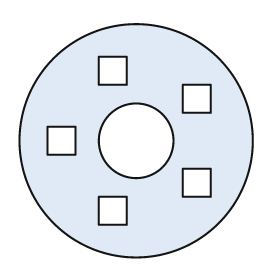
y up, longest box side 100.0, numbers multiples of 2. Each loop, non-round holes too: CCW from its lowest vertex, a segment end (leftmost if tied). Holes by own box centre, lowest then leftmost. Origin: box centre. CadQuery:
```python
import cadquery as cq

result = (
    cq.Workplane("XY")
    .moveTo(0.0, 0.0)
    .circle(50.0)
    .moveTo(-16.0, -36.0)
    .lineTo(-4.0, -36.0)
    .lineTo(-4.0, -24.0)
    .lineTo(-16.0, -24.0)
    .close()
    .moveTo(20.0, -24.0)
    .lineTo(32.0, -24.0)
    .lineTo(32.0, -12.0)
    .lineTo(20.0, -12.0)
    .close()
    .moveTo(-38.0, -6.0)
    .lineTo(-26.0, -6.0)
    .lineTo(-26.0, 6.0)
    .lineTo(-38.0, 6.0)
    .close()
    .moveTo(0.0, 0.0)
    .circle(16.0)
    .moveTo(20.0, 12.0)
    .lineTo(32.0, 12.0)
    .lineTo(32.0, 24.0)
    .lineTo(20.0, 24.0)
    .close()
    .moveTo(-16.0, 24.0)
    .lineTo(-4.0, 24.0)
    .lineTo(-4.0, 36.0)
    .lineTo(-16.0, 36.0)
    .close()
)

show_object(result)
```